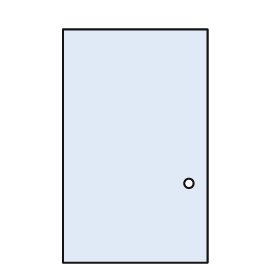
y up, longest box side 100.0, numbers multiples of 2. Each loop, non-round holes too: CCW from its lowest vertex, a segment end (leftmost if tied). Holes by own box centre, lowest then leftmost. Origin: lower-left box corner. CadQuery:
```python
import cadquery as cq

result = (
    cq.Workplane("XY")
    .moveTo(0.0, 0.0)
    .lineTo(62.0, 0.0)
    .lineTo(62.0, 100.0)
    .lineTo(0.0, 100.0)
    .close()
    .moveTo(54.0, 34.0)
    .circle(2.0)
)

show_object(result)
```